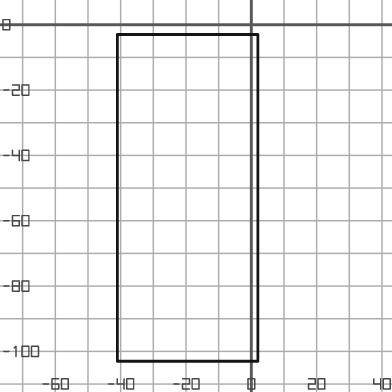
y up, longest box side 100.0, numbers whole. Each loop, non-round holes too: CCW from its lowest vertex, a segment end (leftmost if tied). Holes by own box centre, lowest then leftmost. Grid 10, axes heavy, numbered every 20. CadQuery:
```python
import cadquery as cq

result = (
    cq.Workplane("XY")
    .moveTo(-41.0, -103.0)
    .lineTo(2.0, -103.0)
    .lineTo(2.0, -3.0)
    .lineTo(-41.0, -3.0)
    .close()
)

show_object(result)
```